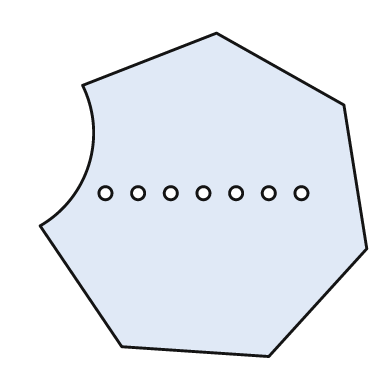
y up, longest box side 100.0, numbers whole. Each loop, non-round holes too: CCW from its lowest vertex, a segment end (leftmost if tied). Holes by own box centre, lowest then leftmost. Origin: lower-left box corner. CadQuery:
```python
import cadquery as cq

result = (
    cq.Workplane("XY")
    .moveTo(70.0, 0.0)
    .lineTo(100.0, 33.0)
    .lineTo(93.0, 77.0)
    .lineTo(54.0, 99.0)
    .lineTo(13.0, 83.0)
    .threePointArc((15.0, 59.0), (0.0, 40.0))
    .lineTo(25.0, 3.0)
    .close()
    .moveTo(20.0, 50.0)
    .circle(2.0)
    .moveTo(30.0, 50.0)
    .circle(2.0)
    .moveTo(40.0, 50.0)
    .circle(2.0)
    .moveTo(50.0, 50.0)
    .circle(2.0)
    .moveTo(60.0, 50.0)
    .circle(2.0)
    .moveTo(70.0, 50.0)
    .circle(2.0)
    .moveTo(80.0, 50.0)
    .circle(2.0)
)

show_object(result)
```